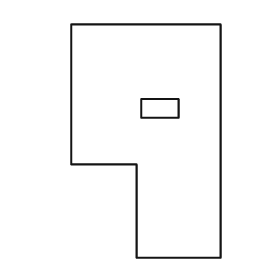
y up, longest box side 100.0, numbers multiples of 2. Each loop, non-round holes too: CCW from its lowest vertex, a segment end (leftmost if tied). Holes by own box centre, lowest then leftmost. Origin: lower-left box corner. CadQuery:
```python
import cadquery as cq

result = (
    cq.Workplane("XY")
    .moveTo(28.0, 0.0)
    .lineTo(64.0, 0.0)
    .lineTo(64.0, 100.0)
    .lineTo(0.0, 100.0)
    .lineTo(0.0, 40.0)
    .lineTo(28.0, 40.0)
    .close()
    .moveTo(30.0, 60.0)
    .lineTo(46.0, 60.0)
    .lineTo(46.0, 68.0)
    .lineTo(30.0, 68.0)
    .close()
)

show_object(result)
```